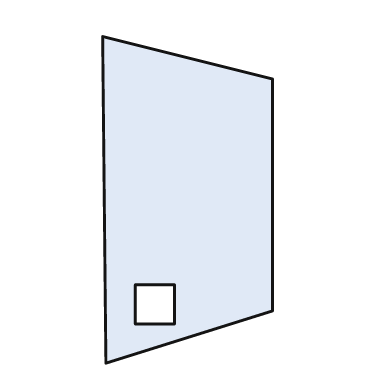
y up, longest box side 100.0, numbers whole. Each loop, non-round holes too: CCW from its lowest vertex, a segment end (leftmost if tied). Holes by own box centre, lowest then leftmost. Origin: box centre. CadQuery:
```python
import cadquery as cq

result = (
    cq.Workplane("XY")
    .moveTo(-25.0, -50.0)
    .lineTo(26.0, -34.0)
    .lineTo(26.0, 37.0)
    .lineTo(-26.0, 50.0)
    .close()
    .moveTo(-16.0, -38.0)
    .lineTo(-4.0, -38.0)
    .lineTo(-4.0, -26.0)
    .lineTo(-16.0, -26.0)
    .close()
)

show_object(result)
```